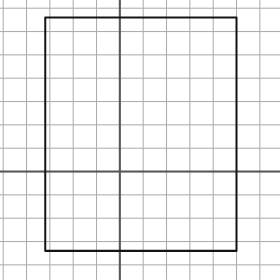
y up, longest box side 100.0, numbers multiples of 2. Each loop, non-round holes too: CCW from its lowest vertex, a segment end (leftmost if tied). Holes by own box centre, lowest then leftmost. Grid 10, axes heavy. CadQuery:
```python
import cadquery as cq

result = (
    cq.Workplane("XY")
    .moveTo(-32.0, -34.0)
    .lineTo(50.0, -34.0)
    .lineTo(50.0, 66.0)
    .lineTo(-32.0, 66.0)
    .close()
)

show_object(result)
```